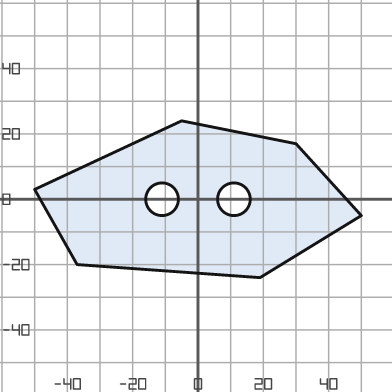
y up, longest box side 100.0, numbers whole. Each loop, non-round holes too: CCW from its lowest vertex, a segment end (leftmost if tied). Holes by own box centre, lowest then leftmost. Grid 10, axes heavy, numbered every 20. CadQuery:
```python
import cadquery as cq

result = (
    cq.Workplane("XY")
    .moveTo(19.0, -24.0)
    .lineTo(50.0, -5.0)
    .lineTo(30.0, 17.0)
    .lineTo(-5.0, 24.0)
    .lineTo(-50.0, 3.0)
    .lineTo(-37.0, -20.0)
    .close()
    .moveTo(-11.0, 0.0)
    .circle(5.0)
    .moveTo(11.0, 0.0)
    .circle(5.0)
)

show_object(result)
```